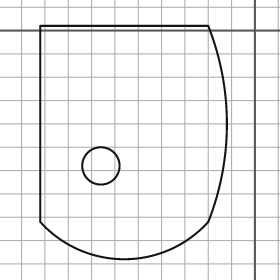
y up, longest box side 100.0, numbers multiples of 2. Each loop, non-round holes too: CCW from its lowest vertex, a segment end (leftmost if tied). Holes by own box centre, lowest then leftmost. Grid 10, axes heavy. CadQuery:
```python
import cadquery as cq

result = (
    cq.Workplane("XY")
    .moveTo(-92.0, -82.0)
    .threePointArc((-56.0, -98.0), (-20.0, -82.0))
    .threePointArc((-12.0, -40.0), (-20.0, 2.0))
    .lineTo(-92.0, 2.0)
    .close()
    .moveTo(-66.0, -58.0)
    .circle(8.0)
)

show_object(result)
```